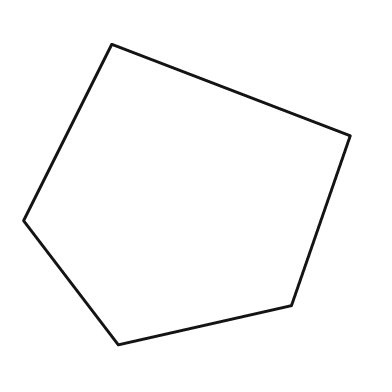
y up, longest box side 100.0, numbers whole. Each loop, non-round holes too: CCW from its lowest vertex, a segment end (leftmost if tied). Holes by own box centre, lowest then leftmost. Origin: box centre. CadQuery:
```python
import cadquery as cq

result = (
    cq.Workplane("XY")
    .moveTo(-21.0, -46.0)
    .lineTo(32.0, -34.0)
    .lineTo(50.0, 18.0)
    .lineTo(-23.0, 46.0)
    .lineTo(-50.0, -8.0)
    .close()
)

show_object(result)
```